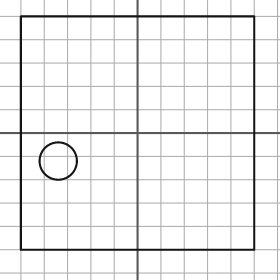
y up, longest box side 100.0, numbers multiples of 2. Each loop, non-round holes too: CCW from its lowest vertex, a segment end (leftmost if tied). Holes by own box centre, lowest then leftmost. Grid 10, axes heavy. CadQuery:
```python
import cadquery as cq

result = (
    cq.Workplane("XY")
    .moveTo(-50.0, -50.0)
    .lineTo(50.0, -50.0)
    .lineTo(50.0, 50.0)
    .lineTo(-50.0, 50.0)
    .close()
    .moveTo(-34.0, -12.0)
    .circle(8.0)
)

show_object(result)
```